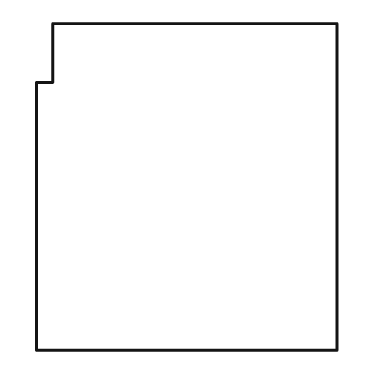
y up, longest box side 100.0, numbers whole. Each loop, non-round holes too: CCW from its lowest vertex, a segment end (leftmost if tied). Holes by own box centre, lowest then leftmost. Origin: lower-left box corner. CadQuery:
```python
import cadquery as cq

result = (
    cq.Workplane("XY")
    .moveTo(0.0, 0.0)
    .lineTo(92.0, 0.0)
    .lineTo(92.0, 100.0)
    .lineTo(5.0, 100.0)
    .lineTo(5.0, 82.0)
    .lineTo(0.0, 82.0)
    .close()
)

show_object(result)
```